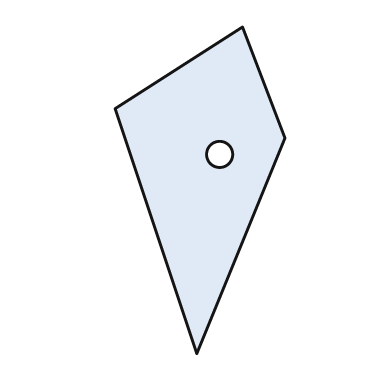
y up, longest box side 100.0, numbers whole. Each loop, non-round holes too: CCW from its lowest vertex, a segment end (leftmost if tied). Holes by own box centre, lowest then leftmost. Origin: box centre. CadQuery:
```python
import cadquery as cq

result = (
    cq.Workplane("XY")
    .moveTo(-1.0, -50.0)
    .lineTo(26.0, 16.0)
    .lineTo(13.0, 50.0)
    .lineTo(-26.0, 25.0)
    .close()
    .moveTo(6.0, 11.0)
    .circle(4.0)
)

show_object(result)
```